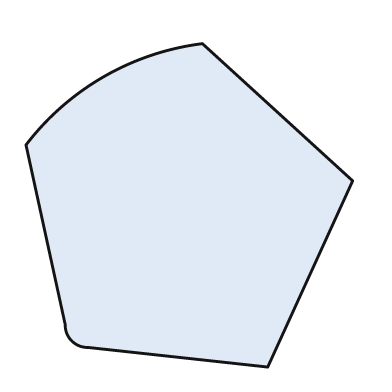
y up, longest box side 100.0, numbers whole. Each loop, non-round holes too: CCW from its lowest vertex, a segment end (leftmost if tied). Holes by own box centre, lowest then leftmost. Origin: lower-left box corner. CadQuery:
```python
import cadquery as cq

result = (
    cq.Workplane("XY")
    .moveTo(74.0, 0.0)
    .lineTo(100.0, 57.0)
    .lineTo(54.0, 99.0)
    .threePointArc((24.0, 89.0), (0.0, 68.0))
    .lineTo(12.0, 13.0)
    .threePointArc((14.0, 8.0), (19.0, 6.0))
    .close()
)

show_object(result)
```